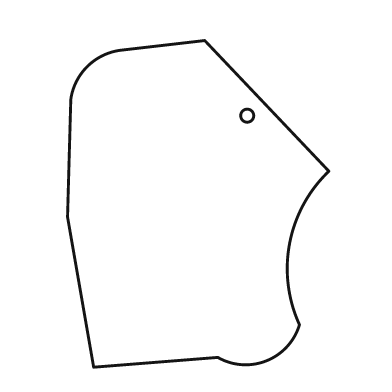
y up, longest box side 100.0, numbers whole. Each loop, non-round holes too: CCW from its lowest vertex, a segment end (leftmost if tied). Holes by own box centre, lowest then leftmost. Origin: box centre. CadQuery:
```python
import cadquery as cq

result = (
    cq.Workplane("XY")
    .moveTo(-32.0, -50.0)
    .lineTo(6.0, -47.0)
    .threePointArc((21.0, -48.0), (31.0, -37.0))
    .threePointArc((28.0, -12.0), (40.0, 10.0))
    .lineTo(2.0, 50.0)
    .lineTo(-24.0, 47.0)
    .threePointArc((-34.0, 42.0), (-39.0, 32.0))
    .lineTo(-40.0, -4.0)
    .close()
    .moveTo(15.0, 27.0)
    .circle(2.0)
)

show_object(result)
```